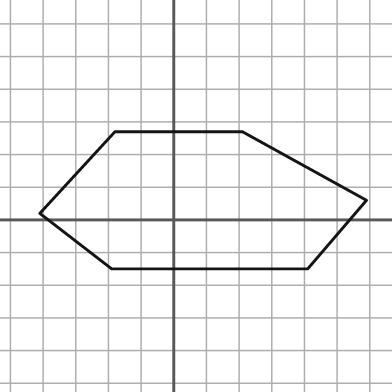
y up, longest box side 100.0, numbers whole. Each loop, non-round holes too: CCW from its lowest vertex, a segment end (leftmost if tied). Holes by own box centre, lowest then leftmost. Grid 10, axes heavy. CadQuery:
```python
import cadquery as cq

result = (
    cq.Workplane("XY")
    .moveTo(-19.0, -15.0)
    .lineTo(41.0, -15.0)
    .lineTo(59.0, 6.0)
    .lineTo(21.0, 27.0)
    .lineTo(-18.0, 27.0)
    .lineTo(-41.0, 2.0)
    .close()
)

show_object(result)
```